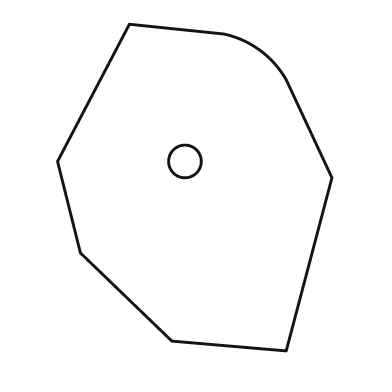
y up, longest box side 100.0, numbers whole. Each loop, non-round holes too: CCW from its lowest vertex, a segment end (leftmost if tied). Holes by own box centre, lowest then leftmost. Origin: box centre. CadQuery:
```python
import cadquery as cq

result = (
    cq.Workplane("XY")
    .moveTo(28.0, -50.0)
    .lineTo(42.0, 3.0)
    .lineTo(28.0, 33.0)
    .threePointArc((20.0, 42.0), (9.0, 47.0))
    .lineTo(-20.0, 50.0)
    .lineTo(-42.0, 8.0)
    .lineTo(-35.0, -20.0)
    .lineTo(-7.0, -47.0)
    .close()
    .moveTo(-3.0, 8.0)
    .circle(5.0)
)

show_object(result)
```